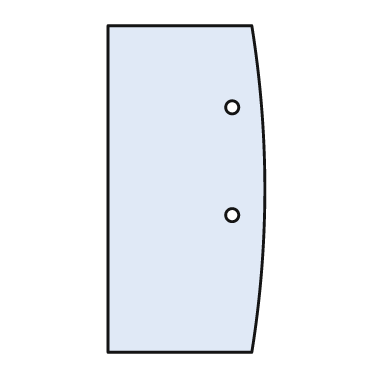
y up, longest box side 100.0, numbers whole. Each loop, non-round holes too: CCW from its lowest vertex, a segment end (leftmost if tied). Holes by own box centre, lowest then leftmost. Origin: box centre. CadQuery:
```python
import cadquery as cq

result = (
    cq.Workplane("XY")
    .moveTo(-24.0, -50.0)
    .lineTo(20.0, -50.0)
    .threePointArc((24.0, 0.0), (20.0, 50.0))
    .lineTo(-24.0, 50.0)
    .close()
    .moveTo(14.0, -8.0)
    .circle(2.0)
    .moveTo(14.0, 25.0)
    .circle(2.0)
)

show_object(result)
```